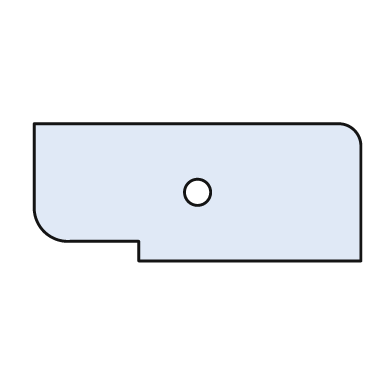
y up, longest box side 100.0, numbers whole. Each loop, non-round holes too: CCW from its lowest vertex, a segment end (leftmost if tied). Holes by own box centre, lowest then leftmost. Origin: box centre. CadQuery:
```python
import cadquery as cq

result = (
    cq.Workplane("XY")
    .moveTo(-18.0, -21.0)
    .lineTo(50.0, -21.0)
    .lineTo(50.0, 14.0)
    .threePointArc((48.0, 19.0), (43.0, 21.0))
    .lineTo(-50.0, 21.0)
    .lineTo(-50.0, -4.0)
    .threePointArc((-47.0, -12.0), (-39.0, -15.0))
    .lineTo(-18.0, -15.0)
    .close()
    .moveTo(0.0, 0.0)
    .circle(4.0)
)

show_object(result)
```